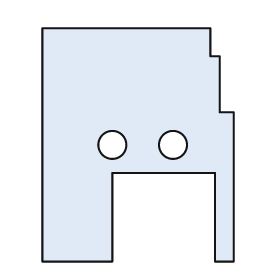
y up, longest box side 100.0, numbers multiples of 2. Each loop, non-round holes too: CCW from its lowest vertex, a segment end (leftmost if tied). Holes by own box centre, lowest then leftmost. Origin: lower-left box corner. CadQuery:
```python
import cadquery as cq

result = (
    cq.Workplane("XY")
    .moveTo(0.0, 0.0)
    .lineTo(30.0, 0.0)
    .lineTo(30.0, 38.0)
    .lineTo(74.0, 38.0)
    .lineTo(74.0, 0.0)
    .lineTo(82.0, 0.0)
    .lineTo(82.0, 64.0)
    .lineTo(76.0, 64.0)
    .lineTo(76.0, 88.0)
    .lineTo(72.0, 88.0)
    .lineTo(72.0, 100.0)
    .lineTo(0.0, 100.0)
    .close()
    .moveTo(30.0, 50.0)
    .circle(6.0)
    .moveTo(56.0, 50.0)
    .circle(6.0)
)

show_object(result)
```